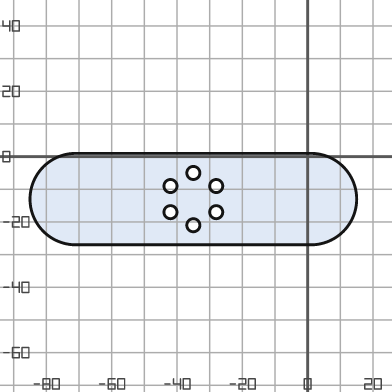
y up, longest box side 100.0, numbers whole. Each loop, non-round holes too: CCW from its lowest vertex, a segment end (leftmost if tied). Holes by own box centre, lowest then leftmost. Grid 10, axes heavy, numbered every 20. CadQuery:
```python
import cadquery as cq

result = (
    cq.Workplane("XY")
    .moveTo(-71.0, -27.0)
    .lineTo(1.0, -27.0)
    .threePointArc((15.0, -13.0), (1.0, 1.0))
    .lineTo(-71.0, 1.0)
    .threePointArc((-85.0, -13.0), (-71.0, -27.0))
    .close()
    .moveTo(-35.0, -21.0)
    .circle(2.0)
    .moveTo(-42.0, -17.0)
    .circle(2.0)
    .moveTo(-28.0, -17.0)
    .circle(2.0)
    .moveTo(-42.0, -9.0)
    .circle(2.0)
    .moveTo(-28.0, -9.0)
    .circle(2.0)
    .moveTo(-35.0, -5.0)
    .circle(2.0)
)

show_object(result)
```